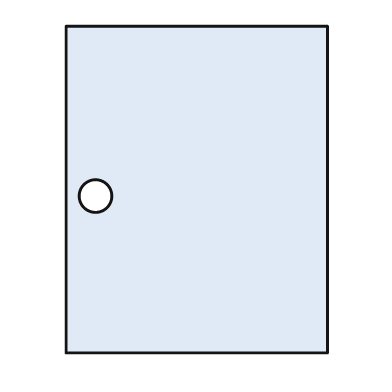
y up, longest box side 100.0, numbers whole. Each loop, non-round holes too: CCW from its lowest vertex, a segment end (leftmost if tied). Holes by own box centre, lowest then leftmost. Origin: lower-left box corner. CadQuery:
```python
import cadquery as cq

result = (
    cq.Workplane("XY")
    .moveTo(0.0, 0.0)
    .lineTo(80.0, 0.0)
    .lineTo(80.0, 100.0)
    .lineTo(0.0, 100.0)
    .close()
    .moveTo(9.0, 48.0)
    .circle(5.0)
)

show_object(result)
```